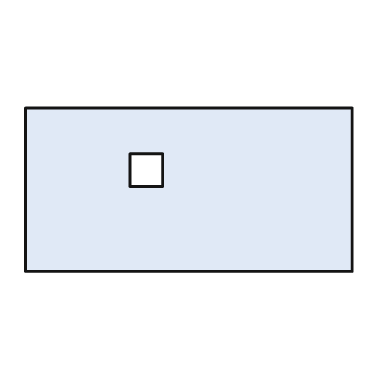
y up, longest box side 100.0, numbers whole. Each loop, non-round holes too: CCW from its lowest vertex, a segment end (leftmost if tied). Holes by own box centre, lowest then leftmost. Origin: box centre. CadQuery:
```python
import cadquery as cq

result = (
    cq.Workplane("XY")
    .moveTo(-50.0, -25.0)
    .lineTo(50.0, -25.0)
    .lineTo(50.0, 25.0)
    .lineTo(-50.0, 25.0)
    .close()
    .moveTo(-18.0, 1.0)
    .lineTo(-8.0, 1.0)
    .lineTo(-8.0, 11.0)
    .lineTo(-18.0, 11.0)
    .close()
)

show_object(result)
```